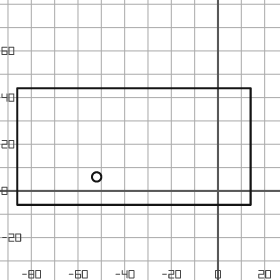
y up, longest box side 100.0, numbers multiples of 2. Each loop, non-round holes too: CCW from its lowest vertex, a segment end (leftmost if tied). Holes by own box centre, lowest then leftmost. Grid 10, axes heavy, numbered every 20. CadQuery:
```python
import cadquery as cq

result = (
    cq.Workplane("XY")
    .moveTo(-86.0, -6.0)
    .lineTo(14.0, -6.0)
    .lineTo(14.0, 44.0)
    .lineTo(-86.0, 44.0)
    .close()
    .moveTo(-52.0, 6.0)
    .circle(2.0)
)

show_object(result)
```